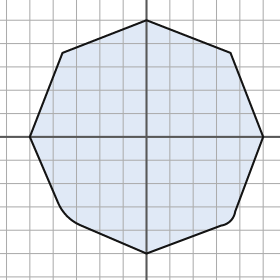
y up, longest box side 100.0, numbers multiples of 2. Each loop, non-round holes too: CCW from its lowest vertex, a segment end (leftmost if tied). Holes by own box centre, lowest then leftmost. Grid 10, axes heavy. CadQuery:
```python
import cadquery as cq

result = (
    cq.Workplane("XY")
    .moveTo(0.0, -50.0)
    .lineTo(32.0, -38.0)
    .threePointArc((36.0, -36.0), (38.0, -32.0))
    .lineTo(50.0, 0.0)
    .lineTo(36.0, 36.0)
    .lineTo(0.0, 50.0)
    .lineTo(-36.0, 36.0)
    .lineTo(-50.0, 0.0)
    .lineTo(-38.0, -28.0)
    .threePointArc((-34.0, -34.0), (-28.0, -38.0))
    .close()
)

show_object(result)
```